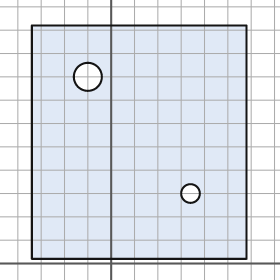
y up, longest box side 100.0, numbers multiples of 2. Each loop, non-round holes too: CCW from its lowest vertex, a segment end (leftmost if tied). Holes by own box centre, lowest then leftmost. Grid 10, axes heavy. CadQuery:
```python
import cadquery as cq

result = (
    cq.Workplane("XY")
    .moveTo(-34.0, 2.0)
    .lineTo(58.0, 2.0)
    .lineTo(58.0, 102.0)
    .lineTo(-34.0, 102.0)
    .close()
    .moveTo(34.0, 30.0)
    .circle(4.0)
    .moveTo(-10.0, 80.0)
    .circle(6.0)
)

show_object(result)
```